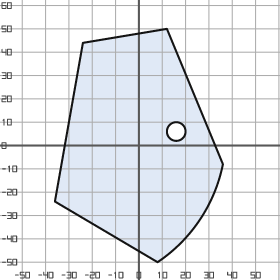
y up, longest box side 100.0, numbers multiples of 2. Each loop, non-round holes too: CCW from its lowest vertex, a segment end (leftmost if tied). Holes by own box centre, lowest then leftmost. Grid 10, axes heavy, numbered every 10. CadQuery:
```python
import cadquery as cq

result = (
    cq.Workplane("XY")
    .moveTo(8.0, -50.0)
    .threePointArc((26.0, -32.0), (36.0, -8.0))
    .lineTo(12.0, 50.0)
    .lineTo(-24.0, 44.0)
    .lineTo(-36.0, -24.0)
    .close()
    .moveTo(16.0, 6.0)
    .circle(4.0)
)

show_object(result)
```